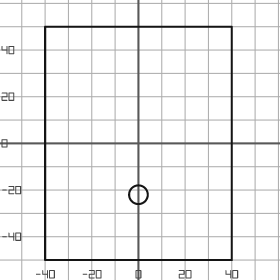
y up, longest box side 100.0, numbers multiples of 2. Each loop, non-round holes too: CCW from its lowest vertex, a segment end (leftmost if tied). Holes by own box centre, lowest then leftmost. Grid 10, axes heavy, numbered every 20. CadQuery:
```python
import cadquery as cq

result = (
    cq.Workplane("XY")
    .moveTo(-40.0, -50.0)
    .lineTo(40.0, -50.0)
    .lineTo(40.0, 50.0)
    .lineTo(-40.0, 50.0)
    .close()
    .moveTo(0.0, -22.0)
    .circle(4.0)
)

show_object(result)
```